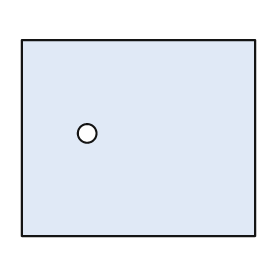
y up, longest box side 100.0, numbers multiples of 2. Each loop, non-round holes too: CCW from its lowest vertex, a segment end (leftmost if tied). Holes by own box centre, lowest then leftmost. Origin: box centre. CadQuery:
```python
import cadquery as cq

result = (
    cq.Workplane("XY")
    .moveTo(-50.0, -42.0)
    .lineTo(50.0, -42.0)
    .lineTo(50.0, 42.0)
    .lineTo(-50.0, 42.0)
    .close()
    .moveTo(-22.0, 2.0)
    .circle(4.0)
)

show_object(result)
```